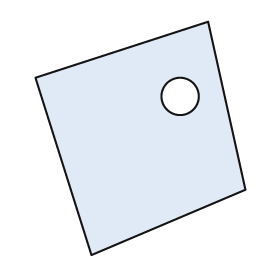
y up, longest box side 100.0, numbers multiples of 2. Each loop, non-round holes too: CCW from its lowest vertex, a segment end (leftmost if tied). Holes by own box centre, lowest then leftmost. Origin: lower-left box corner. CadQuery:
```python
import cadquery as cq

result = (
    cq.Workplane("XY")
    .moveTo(24.0, 0.0)
    .lineTo(90.0, 28.0)
    .lineTo(74.0, 100.0)
    .lineTo(0.0, 76.0)
    .close()
    .moveTo(62.0, 68.0)
    .circle(8.0)
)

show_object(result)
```